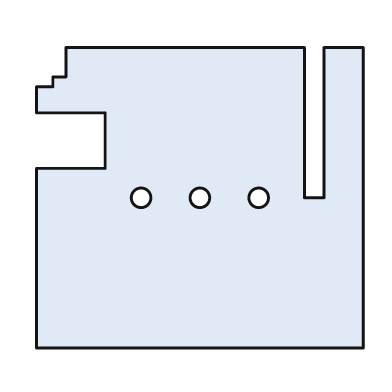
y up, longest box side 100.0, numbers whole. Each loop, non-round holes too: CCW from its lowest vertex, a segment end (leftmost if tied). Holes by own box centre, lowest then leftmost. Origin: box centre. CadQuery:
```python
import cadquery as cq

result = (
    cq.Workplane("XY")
    .moveTo(-50.0, -46.0)
    .lineTo(50.0, -46.0)
    .lineTo(50.0, 46.0)
    .lineTo(38.0, 46.0)
    .lineTo(38.0, 0.0)
    .lineTo(32.0, 0.0)
    .lineTo(32.0, 46.0)
    .lineTo(-41.0, 46.0)
    .lineTo(-41.0, 37.0)
    .lineTo(-45.0, 37.0)
    .lineTo(-45.0, 34.0)
    .lineTo(-50.0, 34.0)
    .lineTo(-50.0, 26.0)
    .lineTo(-29.0, 26.0)
    .lineTo(-29.0, 9.0)
    .lineTo(-50.0, 9.0)
    .close()
    .moveTo(-18.0, 0.0)
    .circle(3.0)
    .moveTo(0.0, 0.0)
    .circle(3.0)
    .moveTo(18.0, 0.0)
    .circle(3.0)
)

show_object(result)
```